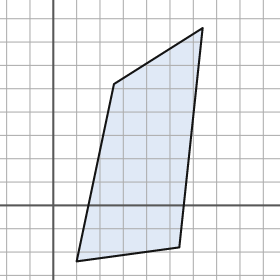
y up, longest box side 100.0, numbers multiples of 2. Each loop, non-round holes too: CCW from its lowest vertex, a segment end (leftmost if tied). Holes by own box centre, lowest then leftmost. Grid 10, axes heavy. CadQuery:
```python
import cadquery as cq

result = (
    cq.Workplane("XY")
    .moveTo(10.0, -24.0)
    .lineTo(54.0, -18.0)
    .lineTo(64.0, 76.0)
    .lineTo(26.0, 52.0)
    .close()
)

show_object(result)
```